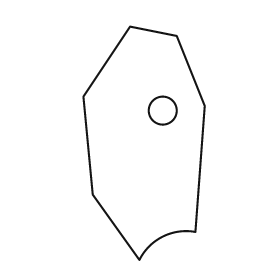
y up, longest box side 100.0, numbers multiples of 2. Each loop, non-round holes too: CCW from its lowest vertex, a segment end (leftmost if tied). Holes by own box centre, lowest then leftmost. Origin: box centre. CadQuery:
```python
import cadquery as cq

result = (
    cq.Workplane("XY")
    .moveTo(-2.0, -50.0)
    .threePointArc((8.0, -40.0), (22.0, -38.0))
    .lineTo(26.0, 16.0)
    .lineTo(14.0, 46.0)
    .lineTo(-6.0, 50.0)
    .lineTo(-26.0, 20.0)
    .lineTo(-22.0, -22.0)
    .close()
    .moveTo(8.0, 14.0)
    .circle(6.0)
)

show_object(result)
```